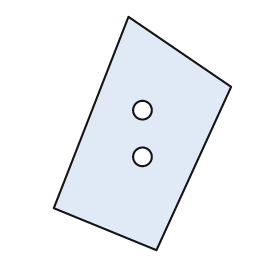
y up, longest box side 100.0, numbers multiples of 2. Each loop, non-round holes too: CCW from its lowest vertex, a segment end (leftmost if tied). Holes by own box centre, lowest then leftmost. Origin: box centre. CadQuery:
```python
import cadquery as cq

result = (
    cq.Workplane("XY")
    .moveTo(6.0, -50.0)
    .lineTo(38.0, 20.0)
    .lineTo(-6.0, 50.0)
    .lineTo(-38.0, -32.0)
    .close()
    .moveTo(0.0, -10.0)
    .circle(4.0)
    .moveTo(0.0, 10.0)
    .circle(4.0)
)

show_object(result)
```